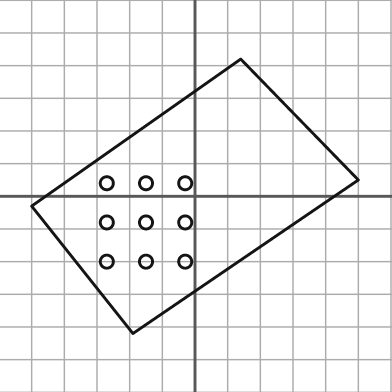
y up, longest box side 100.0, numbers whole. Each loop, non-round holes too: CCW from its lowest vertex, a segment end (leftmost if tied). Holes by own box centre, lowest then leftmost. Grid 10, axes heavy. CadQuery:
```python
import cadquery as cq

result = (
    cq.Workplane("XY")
    .moveTo(-19.0, -42.0)
    .lineTo(50.0, 5.0)
    .lineTo(14.0, 42.0)
    .lineTo(-50.0, -3.0)
    .close()
    .moveTo(-27.0, -20.0)
    .circle(2.0)
    .moveTo(-15.0, -20.0)
    .circle(2.0)
    .moveTo(-3.0, -20.0)
    .circle(2.0)
    .moveTo(-27.0, -8.0)
    .circle(2.0)
    .moveTo(-15.0, -8.0)
    .circle(2.0)
    .moveTo(-3.0, -8.0)
    .circle(2.0)
    .moveTo(-27.0, 4.0)
    .circle(2.0)
    .moveTo(-15.0, 4.0)
    .circle(2.0)
    .moveTo(-3.0, 4.0)
    .circle(2.0)
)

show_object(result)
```